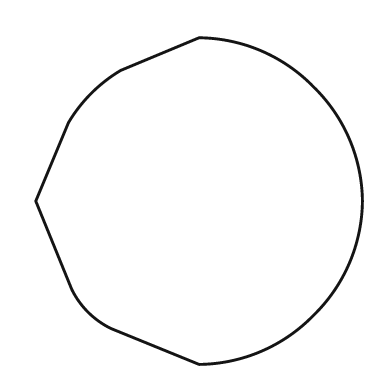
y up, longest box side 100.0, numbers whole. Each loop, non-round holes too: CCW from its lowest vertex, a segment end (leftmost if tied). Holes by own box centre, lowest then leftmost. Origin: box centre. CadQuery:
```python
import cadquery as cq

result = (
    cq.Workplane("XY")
    .moveTo(0.0, -50.0)
    .threePointArc((19.0, -46.0), (35.0, -35.0))
    .threePointArc((46.0, -19.0), (50.0, 0.0))
    .threePointArc((46.0, 19.0), (35.0, 35.0))
    .threePointArc((19.0, 46.0), (0.0, 50.0))
    .lineTo(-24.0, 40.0)
    .threePointArc((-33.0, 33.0), (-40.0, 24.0))
    .lineTo(-50.0, 0.0)
    .lineTo(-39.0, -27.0)
    .threePointArc((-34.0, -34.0), (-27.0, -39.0))
    .close()
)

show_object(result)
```